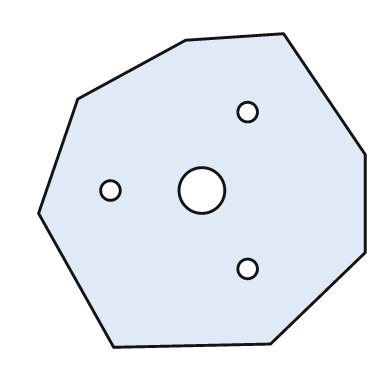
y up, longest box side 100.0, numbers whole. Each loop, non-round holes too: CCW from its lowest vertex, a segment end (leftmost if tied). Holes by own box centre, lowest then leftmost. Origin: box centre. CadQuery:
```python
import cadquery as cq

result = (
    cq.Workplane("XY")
    .moveTo(-27.0, -48.0)
    .lineTo(21.0, -47.0)
    .lineTo(50.0, -19.0)
    .lineTo(50.0, 11.0)
    .lineTo(25.0, 48.0)
    .lineTo(-5.0, 46.0)
    .lineTo(-38.0, 28.0)
    .lineTo(-50.0, -7.0)
    .close()
    .moveTo(14.0, -24.0)
    .circle(3.0)
    .moveTo(-28.0, 0.0)
    .circle(3.0)
    .moveTo(0.0, 0.0)
    .circle(7.0)
    .moveTo(14.0, 24.0)
    .circle(3.0)
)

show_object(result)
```